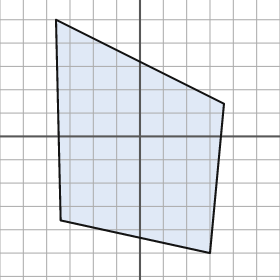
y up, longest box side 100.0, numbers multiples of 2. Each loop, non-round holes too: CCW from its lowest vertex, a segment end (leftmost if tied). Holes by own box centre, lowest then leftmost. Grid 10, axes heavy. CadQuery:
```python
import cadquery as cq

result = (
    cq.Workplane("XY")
    .moveTo(30.0, -50.0)
    .lineTo(36.0, 14.0)
    .lineTo(-36.0, 50.0)
    .lineTo(-34.0, -36.0)
    .close()
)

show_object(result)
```